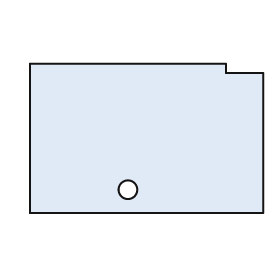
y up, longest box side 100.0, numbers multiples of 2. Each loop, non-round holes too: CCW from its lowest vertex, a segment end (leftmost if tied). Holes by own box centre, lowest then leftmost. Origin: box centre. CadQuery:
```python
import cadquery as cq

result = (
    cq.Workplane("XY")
    .moveTo(-50.0, -32.0)
    .lineTo(50.0, -32.0)
    .lineTo(50.0, 28.0)
    .lineTo(34.0, 28.0)
    .lineTo(34.0, 32.0)
    .lineTo(-50.0, 32.0)
    .close()
    .moveTo(-8.0, -22.0)
    .circle(4.0)
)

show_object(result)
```